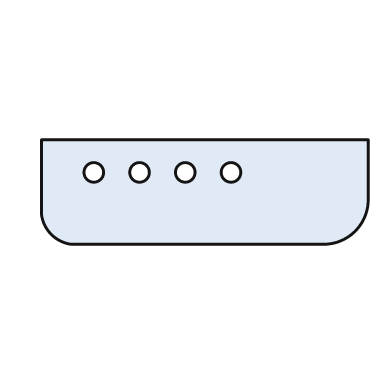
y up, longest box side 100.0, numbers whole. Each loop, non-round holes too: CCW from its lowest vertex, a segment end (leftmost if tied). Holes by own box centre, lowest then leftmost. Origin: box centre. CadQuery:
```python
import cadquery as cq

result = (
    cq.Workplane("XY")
    .moveTo(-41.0, -16.0)
    .lineTo(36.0, -16.0)
    .threePointArc((46.0, -12.0), (50.0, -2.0))
    .lineTo(50.0, 16.0)
    .lineTo(-50.0, 16.0)
    .lineTo(-50.0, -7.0)
    .threePointArc((-47.0, -13.0), (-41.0, -16.0))
    .close()
    .moveTo(-34.0, 6.0)
    .circle(3.0)
    .moveTo(-20.0, 6.0)
    .circle(3.0)
    .moveTo(-6.0, 6.0)
    .circle(3.0)
    .moveTo(8.0, 6.0)
    .circle(3.0)
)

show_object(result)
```